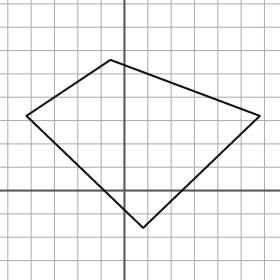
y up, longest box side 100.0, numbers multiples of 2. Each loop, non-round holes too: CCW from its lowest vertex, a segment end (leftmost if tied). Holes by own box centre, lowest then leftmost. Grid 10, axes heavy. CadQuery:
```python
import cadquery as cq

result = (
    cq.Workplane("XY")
    .moveTo(8.0, -16.0)
    .lineTo(58.0, 32.0)
    .lineTo(-6.0, 56.0)
    .lineTo(-42.0, 32.0)
    .close()
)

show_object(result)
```